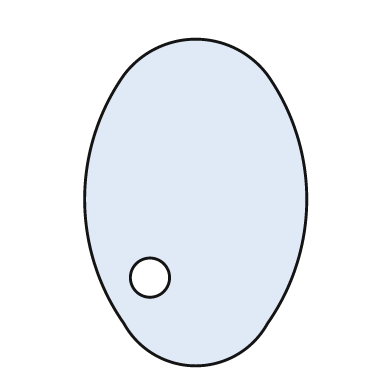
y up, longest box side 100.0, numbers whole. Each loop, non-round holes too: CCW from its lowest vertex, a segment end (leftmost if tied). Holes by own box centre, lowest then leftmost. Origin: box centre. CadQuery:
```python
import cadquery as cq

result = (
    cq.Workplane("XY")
    .moveTo(-22.0, -37.0)
    .threePointArc((0.0, -50.0), (22.0, -37.0))
    .threePointArc((34.0, 1.0), (22.0, 39.0))
    .threePointArc((0.0, 50.0), (-22.0, 39.0))
    .threePointArc((-34.0, 1.0), (-22.0, -37.0))
    .close()
    .moveTo(-14.0, -23.0)
    .circle(6.0)
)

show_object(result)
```